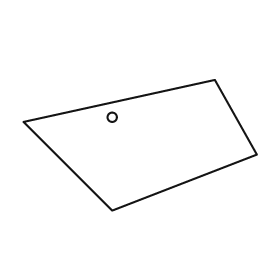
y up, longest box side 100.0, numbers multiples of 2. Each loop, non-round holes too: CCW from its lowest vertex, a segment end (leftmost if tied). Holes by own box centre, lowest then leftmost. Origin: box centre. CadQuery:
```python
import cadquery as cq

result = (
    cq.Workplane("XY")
    .moveTo(-12.0, -28.0)
    .lineTo(50.0, -4.0)
    .lineTo(32.0, 28.0)
    .lineTo(-50.0, 10.0)
    .close()
    .moveTo(-12.0, 12.0)
    .circle(2.0)
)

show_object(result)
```